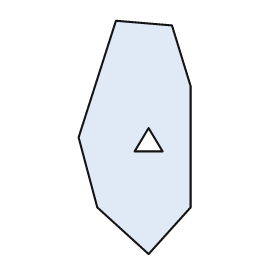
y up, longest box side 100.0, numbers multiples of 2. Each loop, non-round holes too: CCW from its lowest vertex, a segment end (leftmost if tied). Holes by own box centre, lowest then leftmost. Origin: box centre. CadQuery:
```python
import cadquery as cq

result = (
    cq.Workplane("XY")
    .moveTo(6.0, -50.0)
    .lineTo(24.0, -30.0)
    .lineTo(24.0, 22.0)
    .lineTo(16.0, 48.0)
    .lineTo(-8.0, 50.0)
    .lineTo(-24.0, 0.0)
    .lineTo(-16.0, -30.0)
    .close()
    .moveTo(0.0, -6.0)
    .lineTo(12.0, -6.0)
    .lineTo(6.0, 4.0)
    .close()
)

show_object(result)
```